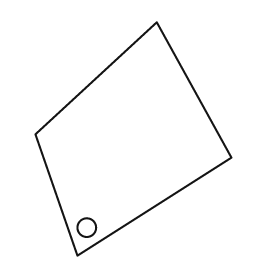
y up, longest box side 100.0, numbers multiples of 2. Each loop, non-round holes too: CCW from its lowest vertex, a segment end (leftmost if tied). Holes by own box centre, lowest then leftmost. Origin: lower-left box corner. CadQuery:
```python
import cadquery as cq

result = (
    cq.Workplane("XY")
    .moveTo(18.0, 0.0)
    .lineTo(84.0, 42.0)
    .lineTo(52.0, 100.0)
    .lineTo(0.0, 52.0)
    .close()
    .moveTo(22.0, 12.0)
    .circle(4.0)
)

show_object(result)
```